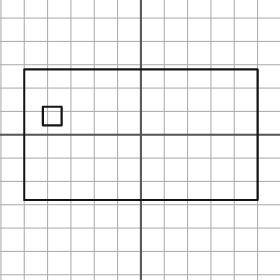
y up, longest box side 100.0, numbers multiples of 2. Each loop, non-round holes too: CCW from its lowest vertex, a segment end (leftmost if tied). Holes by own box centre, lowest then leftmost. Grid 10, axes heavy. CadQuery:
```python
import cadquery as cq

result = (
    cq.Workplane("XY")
    .moveTo(-50.0, -28.0)
    .lineTo(50.0, -28.0)
    .lineTo(50.0, 28.0)
    .lineTo(-50.0, 28.0)
    .close()
    .moveTo(-42.0, 4.0)
    .lineTo(-34.0, 4.0)
    .lineTo(-34.0, 12.0)
    .lineTo(-42.0, 12.0)
    .close()
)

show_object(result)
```